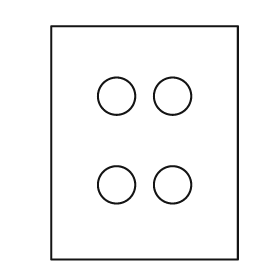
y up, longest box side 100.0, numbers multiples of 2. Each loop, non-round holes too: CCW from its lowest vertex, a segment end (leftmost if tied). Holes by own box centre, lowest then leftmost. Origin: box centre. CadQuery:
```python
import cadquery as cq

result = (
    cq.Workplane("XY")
    .moveTo(-40.0, -50.0)
    .lineTo(40.0, -50.0)
    .lineTo(40.0, 50.0)
    .lineTo(-40.0, 50.0)
    .close()
    .moveTo(-12.0, -18.0)
    .circle(8.0)
    .moveTo(12.0, -18.0)
    .circle(8.0)
    .moveTo(-12.0, 20.0)
    .circle(8.0)
    .moveTo(12.0, 20.0)
    .circle(8.0)
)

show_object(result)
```